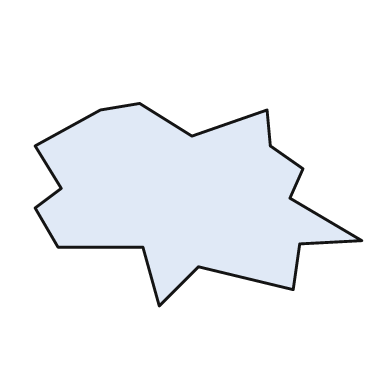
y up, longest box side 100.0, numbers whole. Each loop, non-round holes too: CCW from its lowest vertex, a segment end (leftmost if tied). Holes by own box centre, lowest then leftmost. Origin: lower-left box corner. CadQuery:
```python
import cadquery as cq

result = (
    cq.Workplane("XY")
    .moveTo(38.0, 0.0)
    .lineTo(50.0, 12.0)
    .lineTo(79.0, 5.0)
    .lineTo(81.0, 19.0)
    .lineTo(100.0, 20.0)
    .lineTo(78.0, 33.0)
    .lineTo(82.0, 42.0)
    .lineTo(72.0, 49.0)
    .lineTo(71.0, 60.0)
    .lineTo(48.0, 52.0)
    .lineTo(32.0, 62.0)
    .lineTo(20.0, 60.0)
    .lineTo(0.0, 49.0)
    .lineTo(8.0, 36.0)
    .lineTo(0.0, 30.0)
    .lineTo(7.0, 18.0)
    .lineTo(33.0, 18.0)
    .close()
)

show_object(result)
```